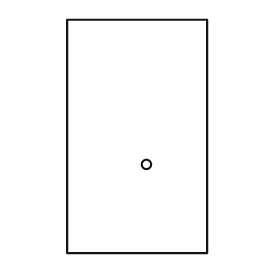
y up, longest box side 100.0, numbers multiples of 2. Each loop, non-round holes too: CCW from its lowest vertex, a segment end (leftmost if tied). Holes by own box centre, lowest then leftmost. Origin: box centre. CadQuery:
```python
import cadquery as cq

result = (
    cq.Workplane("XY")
    .moveTo(-30.0, -50.0)
    .lineTo(30.0, -50.0)
    .lineTo(30.0, 50.0)
    .lineTo(-30.0, 50.0)
    .close()
    .moveTo(4.0, -12.0)
    .circle(2.0)
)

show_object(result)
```